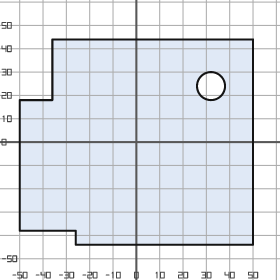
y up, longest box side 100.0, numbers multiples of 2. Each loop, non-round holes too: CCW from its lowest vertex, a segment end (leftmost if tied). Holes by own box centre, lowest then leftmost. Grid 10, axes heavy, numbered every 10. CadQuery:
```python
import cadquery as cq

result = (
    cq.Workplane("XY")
    .moveTo(-26.0, -44.0)
    .lineTo(50.0, -44.0)
    .lineTo(50.0, 44.0)
    .lineTo(-36.0, 44.0)
    .lineTo(-36.0, 18.0)
    .lineTo(-50.0, 18.0)
    .lineTo(-50.0, -38.0)
    .lineTo(-26.0, -38.0)
    .close()
    .moveTo(32.0, 24.0)
    .circle(6.0)
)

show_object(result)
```